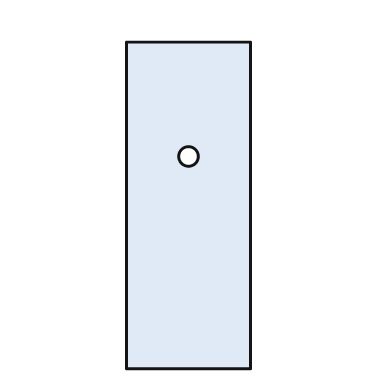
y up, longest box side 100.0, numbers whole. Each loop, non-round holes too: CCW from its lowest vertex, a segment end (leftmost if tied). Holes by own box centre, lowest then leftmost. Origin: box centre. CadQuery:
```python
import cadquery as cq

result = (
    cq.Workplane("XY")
    .moveTo(-19.0, -50.0)
    .lineTo(19.0, -50.0)
    .lineTo(19.0, 50.0)
    .lineTo(-19.0, 50.0)
    .close()
    .moveTo(0.0, 15.0)
    .circle(3.0)
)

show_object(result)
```